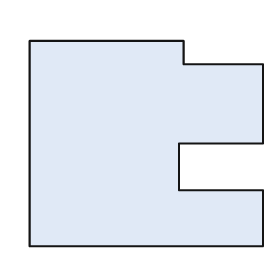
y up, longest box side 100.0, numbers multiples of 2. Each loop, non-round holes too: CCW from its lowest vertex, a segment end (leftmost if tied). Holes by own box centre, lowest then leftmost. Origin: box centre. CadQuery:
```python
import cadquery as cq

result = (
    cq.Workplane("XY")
    .moveTo(-50.0, -44.0)
    .lineTo(50.0, -44.0)
    .lineTo(50.0, -20.0)
    .lineTo(14.0, -20.0)
    .lineTo(14.0, 0.0)
    .lineTo(50.0, 0.0)
    .lineTo(50.0, 34.0)
    .lineTo(16.0, 34.0)
    .lineTo(16.0, 44.0)
    .lineTo(-50.0, 44.0)
    .close()
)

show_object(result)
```